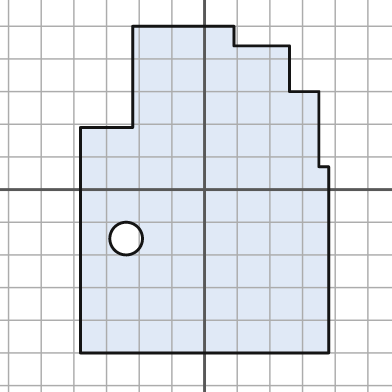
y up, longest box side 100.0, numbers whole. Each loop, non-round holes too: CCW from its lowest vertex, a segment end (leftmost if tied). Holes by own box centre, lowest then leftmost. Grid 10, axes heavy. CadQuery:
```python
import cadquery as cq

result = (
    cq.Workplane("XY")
    .moveTo(-38.0, -50.0)
    .lineTo(38.0, -50.0)
    .lineTo(38.0, 7.0)
    .lineTo(35.0, 7.0)
    .lineTo(35.0, 30.0)
    .lineTo(26.0, 30.0)
    .lineTo(26.0, 44.0)
    .lineTo(9.0, 44.0)
    .lineTo(9.0, 50.0)
    .lineTo(-22.0, 50.0)
    .lineTo(-22.0, 19.0)
    .lineTo(-38.0, 19.0)
    .close()
    .moveTo(-24.0, -15.0)
    .circle(5.0)
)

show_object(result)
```